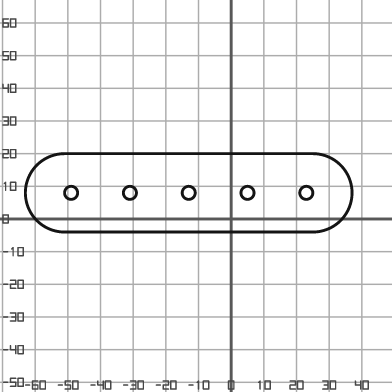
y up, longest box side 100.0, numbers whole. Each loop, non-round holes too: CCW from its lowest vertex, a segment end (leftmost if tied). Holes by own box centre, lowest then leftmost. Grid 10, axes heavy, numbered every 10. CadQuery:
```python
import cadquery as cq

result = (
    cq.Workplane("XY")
    .moveTo(-51.0, -4.0)
    .lineTo(25.0, -4.0)
    .threePointArc((37.0, 8.0), (25.0, 20.0))
    .lineTo(-51.0, 20.0)
    .threePointArc((-63.0, 8.0), (-51.0, -4.0))
    .close()
    .moveTo(-49.0, 8.0)
    .circle(2.0)
    .moveTo(-31.0, 8.0)
    .circle(2.0)
    .moveTo(-13.0, 8.0)
    .circle(2.0)
    .moveTo(5.0, 8.0)
    .circle(2.0)
    .moveTo(23.0, 8.0)
    .circle(2.0)
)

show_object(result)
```